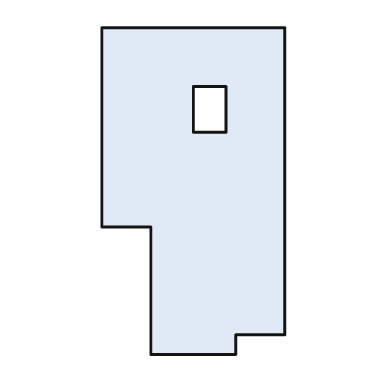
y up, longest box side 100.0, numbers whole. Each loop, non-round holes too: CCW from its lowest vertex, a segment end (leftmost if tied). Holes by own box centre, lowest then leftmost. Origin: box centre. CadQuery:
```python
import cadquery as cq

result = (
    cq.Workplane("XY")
    .moveTo(-13.0, -50.0)
    .lineTo(13.0, -50.0)
    .lineTo(13.0, -44.0)
    .lineTo(28.0, -44.0)
    .lineTo(28.0, 50.0)
    .lineTo(-28.0, 50.0)
    .lineTo(-28.0, -11.0)
    .lineTo(-13.0, -11.0)
    .close()
    .moveTo(0.0, 18.0)
    .lineTo(10.0, 18.0)
    .lineTo(10.0, 32.0)
    .lineTo(0.0, 32.0)
    .close()
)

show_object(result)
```